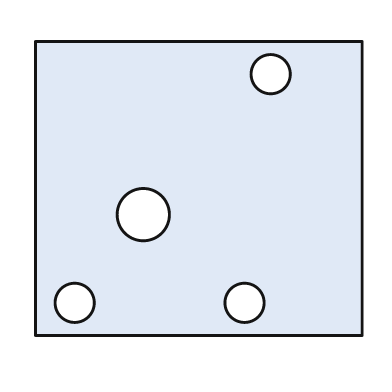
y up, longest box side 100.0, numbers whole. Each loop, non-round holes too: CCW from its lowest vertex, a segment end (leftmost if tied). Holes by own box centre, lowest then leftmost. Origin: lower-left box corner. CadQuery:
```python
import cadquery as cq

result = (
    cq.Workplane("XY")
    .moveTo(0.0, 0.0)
    .lineTo(100.0, 0.0)
    .lineTo(100.0, 90.0)
    .lineTo(0.0, 90.0)
    .close()
    .moveTo(12.0, 10.0)
    .circle(6.0)
    .moveTo(64.0, 10.0)
    .circle(6.0)
    .moveTo(33.0, 37.0)
    .circle(8.0)
    .moveTo(72.0, 80.0)
    .circle(6.0)
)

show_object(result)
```